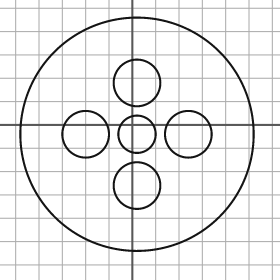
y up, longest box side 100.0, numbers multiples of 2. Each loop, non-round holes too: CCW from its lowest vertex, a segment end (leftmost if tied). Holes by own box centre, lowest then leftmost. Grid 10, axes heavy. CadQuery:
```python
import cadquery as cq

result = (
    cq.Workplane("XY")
    .moveTo(2.0, -4.0)
    .circle(50.0)
    .moveTo(2.0, -26.0)
    .circle(10.0)
    .moveTo(-20.0, -4.0)
    .circle(10.0)
    .moveTo(2.0, -4.0)
    .circle(8.0)
    .moveTo(24.0, -4.0)
    .circle(10.0)
    .moveTo(2.0, 18.0)
    .circle(10.0)
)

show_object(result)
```